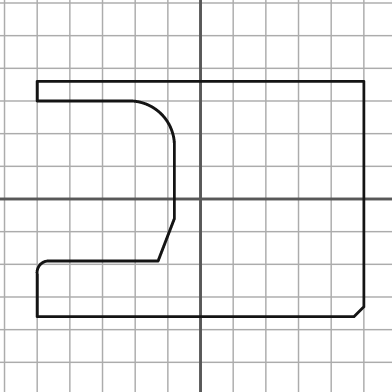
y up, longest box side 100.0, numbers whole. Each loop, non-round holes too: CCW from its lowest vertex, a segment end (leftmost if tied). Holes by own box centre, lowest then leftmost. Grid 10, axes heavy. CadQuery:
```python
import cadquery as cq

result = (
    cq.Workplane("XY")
    .moveTo(-50.0, -36.0)
    .lineTo(47.0, -36.0)
    .lineTo(50.0, -33.0)
    .lineTo(50.0, 36.0)
    .lineTo(-50.0, 36.0)
    .lineTo(-50.0, 30.0)
    .lineTo(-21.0, 30.0)
    .threePointArc((-12.0, 26.0), (-8.0, 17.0))
    .lineTo(-8.0, -6.0)
    .lineTo(-13.0, -19.0)
    .lineTo(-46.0, -19.0)
    .threePointArc((-49.0, -20.0), (-50.0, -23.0))
    .close()
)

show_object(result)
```